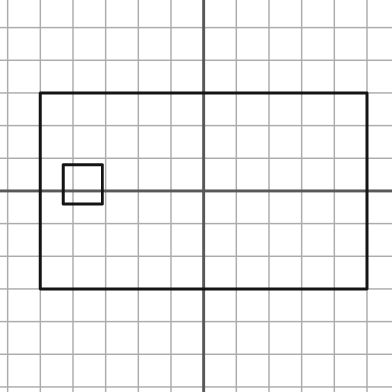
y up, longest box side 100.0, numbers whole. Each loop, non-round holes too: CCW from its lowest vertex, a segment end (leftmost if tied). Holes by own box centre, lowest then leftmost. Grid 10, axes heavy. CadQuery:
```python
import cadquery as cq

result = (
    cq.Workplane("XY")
    .moveTo(-50.0, -30.0)
    .lineTo(50.0, -30.0)
    .lineTo(50.0, 30.0)
    .lineTo(-50.0, 30.0)
    .close()
    .moveTo(-43.0, -4.0)
    .lineTo(-31.0, -4.0)
    .lineTo(-31.0, 8.0)
    .lineTo(-43.0, 8.0)
    .close()
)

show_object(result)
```